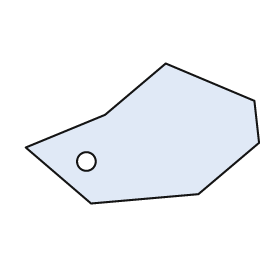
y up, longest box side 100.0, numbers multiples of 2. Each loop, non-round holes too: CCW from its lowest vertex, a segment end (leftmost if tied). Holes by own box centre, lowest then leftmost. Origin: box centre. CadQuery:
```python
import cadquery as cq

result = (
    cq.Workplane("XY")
    .moveTo(-22.0, -30.0)
    .lineTo(24.0, -26.0)
    .lineTo(50.0, -4.0)
    .lineTo(48.0, 14.0)
    .lineTo(10.0, 30.0)
    .lineTo(-16.0, 8.0)
    .lineTo(-50.0, -6.0)
    .close()
    .moveTo(-24.0, -12.0)
    .circle(4.0)
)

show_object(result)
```